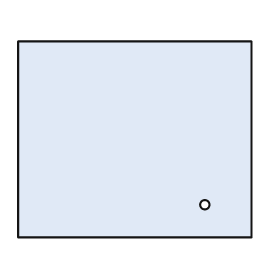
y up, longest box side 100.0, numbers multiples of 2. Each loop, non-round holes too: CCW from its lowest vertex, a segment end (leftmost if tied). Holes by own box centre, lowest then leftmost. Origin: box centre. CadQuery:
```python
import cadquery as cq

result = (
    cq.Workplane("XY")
    .moveTo(-50.0, -42.0)
    .lineTo(50.0, -42.0)
    .lineTo(50.0, 42.0)
    .lineTo(-50.0, 42.0)
    .close()
    .moveTo(30.0, -28.0)
    .circle(2.0)
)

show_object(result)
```